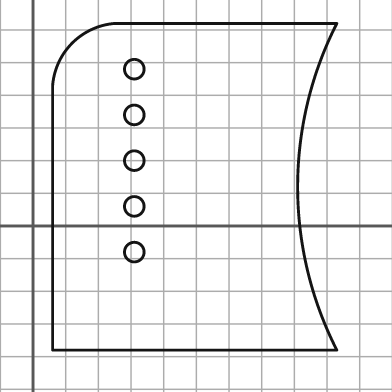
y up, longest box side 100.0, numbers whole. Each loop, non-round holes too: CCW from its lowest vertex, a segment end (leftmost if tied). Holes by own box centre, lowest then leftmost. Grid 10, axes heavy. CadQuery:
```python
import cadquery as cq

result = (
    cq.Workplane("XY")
    .moveTo(6.0, -38.0)
    .lineTo(93.0, -38.0)
    .threePointArc((81.0, 12.0), (93.0, 62.0))
    .lineTo(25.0, 62.0)
    .threePointArc((12.0, 56.0), (6.0, 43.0))
    .close()
    .moveTo(31.0, -8.0)
    .circle(3.0)
    .moveTo(31.0, 6.0)
    .circle(3.0)
    .moveTo(31.0, 20.0)
    .circle(3.0)
    .moveTo(31.0, 34.0)
    .circle(3.0)
    .moveTo(31.0, 48.0)
    .circle(3.0)
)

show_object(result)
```